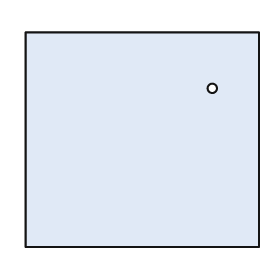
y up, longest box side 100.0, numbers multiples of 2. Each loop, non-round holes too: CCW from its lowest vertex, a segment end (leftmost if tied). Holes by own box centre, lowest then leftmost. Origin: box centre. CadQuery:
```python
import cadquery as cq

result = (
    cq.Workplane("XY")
    .moveTo(-50.0, -46.0)
    .lineTo(50.0, -46.0)
    .lineTo(50.0, 46.0)
    .lineTo(-50.0, 46.0)
    .close()
    .moveTo(30.0, 22.0)
    .circle(2.0)
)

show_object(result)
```